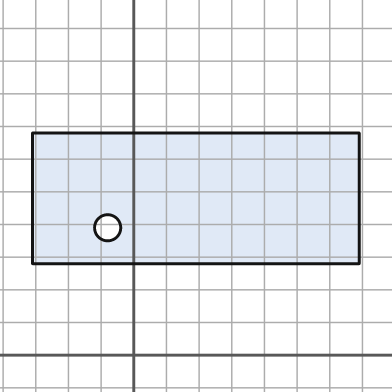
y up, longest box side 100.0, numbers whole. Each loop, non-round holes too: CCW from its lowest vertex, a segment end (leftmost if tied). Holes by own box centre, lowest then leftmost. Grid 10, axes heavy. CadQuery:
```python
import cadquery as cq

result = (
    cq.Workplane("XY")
    .moveTo(-31.0, 28.0)
    .lineTo(69.0, 28.0)
    .lineTo(69.0, 68.0)
    .lineTo(-31.0, 68.0)
    .close()
    .moveTo(-8.0, 39.0)
    .circle(4.0)
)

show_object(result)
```